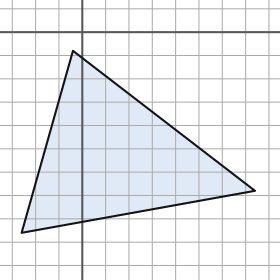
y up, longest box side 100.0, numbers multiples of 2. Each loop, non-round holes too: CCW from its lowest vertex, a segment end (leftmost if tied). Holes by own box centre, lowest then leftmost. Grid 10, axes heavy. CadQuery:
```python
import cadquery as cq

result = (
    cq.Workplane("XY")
    .moveTo(-26.0, -86.0)
    .lineTo(74.0, -68.0)
    .lineTo(-4.0, -8.0)
    .close()
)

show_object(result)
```